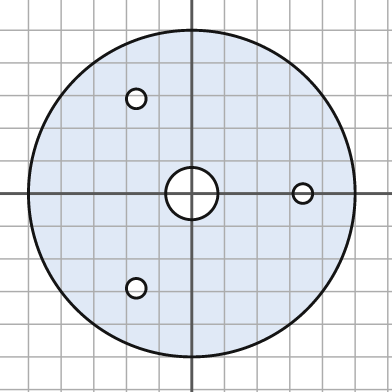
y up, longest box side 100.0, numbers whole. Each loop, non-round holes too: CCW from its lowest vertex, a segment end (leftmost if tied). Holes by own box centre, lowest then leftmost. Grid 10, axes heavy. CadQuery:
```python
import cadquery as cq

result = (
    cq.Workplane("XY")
    .moveTo(0.0, 0.0)
    .circle(50.0)
    .moveTo(-17.0, -29.0)
    .circle(3.0)
    .moveTo(0.0, 0.0)
    .circle(8.0)
    .moveTo(34.0, 0.0)
    .circle(3.0)
    .moveTo(-17.0, 29.0)
    .circle(3.0)
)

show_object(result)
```